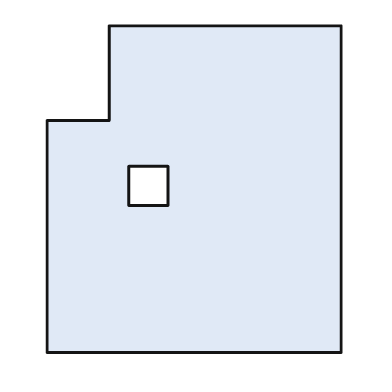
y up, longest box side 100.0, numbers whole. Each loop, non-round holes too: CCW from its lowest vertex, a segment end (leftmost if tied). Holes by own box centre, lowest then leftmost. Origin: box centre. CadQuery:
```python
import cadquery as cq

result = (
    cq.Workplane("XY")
    .moveTo(-45.0, -50.0)
    .lineTo(45.0, -50.0)
    .lineTo(45.0, 50.0)
    .lineTo(-26.0, 50.0)
    .lineTo(-26.0, 21.0)
    .lineTo(-45.0, 21.0)
    .close()
    .moveTo(-20.0, -5.0)
    .lineTo(-8.0, -5.0)
    .lineTo(-8.0, 7.0)
    .lineTo(-20.0, 7.0)
    .close()
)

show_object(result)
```